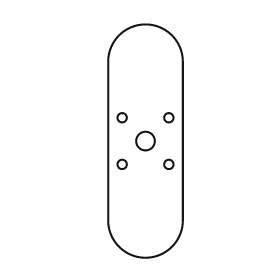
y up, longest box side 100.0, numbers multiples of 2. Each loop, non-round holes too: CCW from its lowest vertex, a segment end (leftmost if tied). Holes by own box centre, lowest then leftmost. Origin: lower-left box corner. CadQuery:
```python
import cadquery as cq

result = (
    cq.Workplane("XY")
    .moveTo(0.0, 16.0)
    .threePointArc((16.0, 0.0), (32.0, 16.0))
    .lineTo(32.0, 84.0)
    .threePointArc((16.0, 100.0), (0.0, 84.0))
    .close()
    .moveTo(6.0, 40.0)
    .circle(2.0)
    .moveTo(26.0, 40.0)
    .circle(2.0)
    .moveTo(16.0, 50.0)
    .circle(4.0)
    .moveTo(6.0, 60.0)
    .circle(2.0)
    .moveTo(26.0, 60.0)
    .circle(2.0)
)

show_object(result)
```